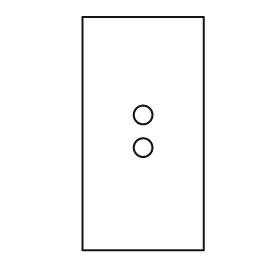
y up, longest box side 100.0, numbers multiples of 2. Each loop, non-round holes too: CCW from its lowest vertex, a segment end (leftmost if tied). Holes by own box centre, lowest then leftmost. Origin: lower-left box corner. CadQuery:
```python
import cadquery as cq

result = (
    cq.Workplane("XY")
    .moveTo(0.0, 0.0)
    .lineTo(52.0, 0.0)
    .lineTo(52.0, 100.0)
    .lineTo(0.0, 100.0)
    .close()
    .moveTo(26.0, 44.0)
    .circle(4.0)
    .moveTo(26.0, 58.0)
    .circle(4.0)
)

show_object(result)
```